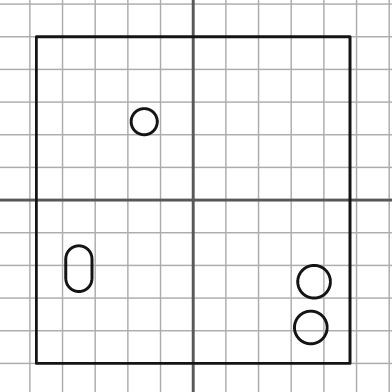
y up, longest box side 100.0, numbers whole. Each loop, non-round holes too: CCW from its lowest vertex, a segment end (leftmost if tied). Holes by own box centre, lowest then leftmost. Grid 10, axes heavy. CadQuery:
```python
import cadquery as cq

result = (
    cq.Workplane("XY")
    .moveTo(-48.0, -50.0)
    .lineTo(48.0, -50.0)
    .lineTo(48.0, 50.0)
    .lineTo(-48.0, 50.0)
    .close()
    .moveTo(36.0, -39.0)
    .circle(5.0)
    .moveTo(37.0, -25.0)
    .circle(5.0)
    .moveTo(-39.0, -24.0)
    .threePointArc((-35.0, -28.0), (-31.0, -24.0))
    .lineTo(-31.0, -18.0)
    .threePointArc((-35.0, -14.0), (-39.0, -18.0))
    .close()
    .moveTo(-15.0, 24.0)
    .circle(4.0)
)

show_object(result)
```